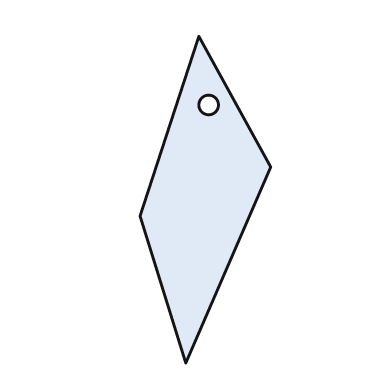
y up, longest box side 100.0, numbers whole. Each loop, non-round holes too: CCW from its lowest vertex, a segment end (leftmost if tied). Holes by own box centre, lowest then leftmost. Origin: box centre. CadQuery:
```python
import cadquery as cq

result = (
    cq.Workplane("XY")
    .moveTo(-6.0, -50.0)
    .lineTo(20.0, 10.0)
    .lineTo(-2.0, 50.0)
    .lineTo(-20.0, -5.0)
    .close()
    .moveTo(1.0, 29.0)
    .circle(3.0)
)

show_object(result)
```